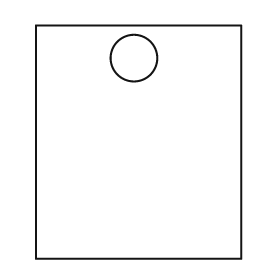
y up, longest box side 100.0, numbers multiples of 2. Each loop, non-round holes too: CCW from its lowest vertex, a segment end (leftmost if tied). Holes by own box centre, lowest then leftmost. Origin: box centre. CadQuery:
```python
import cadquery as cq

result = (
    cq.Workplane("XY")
    .moveTo(-44.0, -50.0)
    .lineTo(44.0, -50.0)
    .lineTo(44.0, 50.0)
    .lineTo(-44.0, 50.0)
    .close()
    .moveTo(-2.0, 36.0)
    .circle(10.0)
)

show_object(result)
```